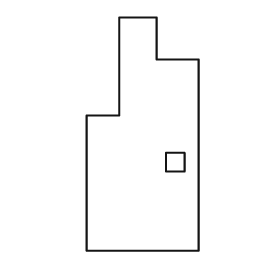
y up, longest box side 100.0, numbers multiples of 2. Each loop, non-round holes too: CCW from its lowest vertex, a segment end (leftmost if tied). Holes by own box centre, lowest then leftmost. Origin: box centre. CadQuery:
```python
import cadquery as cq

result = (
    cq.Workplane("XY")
    .moveTo(-24.0, -50.0)
    .lineTo(24.0, -50.0)
    .lineTo(24.0, 32.0)
    .lineTo(6.0, 32.0)
    .lineTo(6.0, 50.0)
    .lineTo(-10.0, 50.0)
    .lineTo(-10.0, 8.0)
    .lineTo(-24.0, 8.0)
    .close()
    .moveTo(10.0, -16.0)
    .lineTo(18.0, -16.0)
    .lineTo(18.0, -8.0)
    .lineTo(10.0, -8.0)
    .close()
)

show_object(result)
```